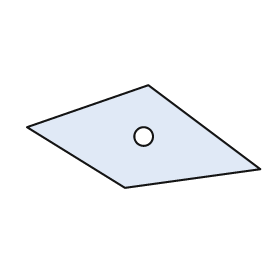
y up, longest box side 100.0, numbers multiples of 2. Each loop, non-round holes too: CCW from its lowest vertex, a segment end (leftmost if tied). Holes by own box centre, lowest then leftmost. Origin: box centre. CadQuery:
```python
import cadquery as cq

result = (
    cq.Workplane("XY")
    .moveTo(-8.0, -22.0)
    .lineTo(50.0, -14.0)
    .lineTo(2.0, 22.0)
    .lineTo(-50.0, 4.0)
    .close()
    .moveTo(0.0, 0.0)
    .circle(4.0)
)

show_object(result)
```